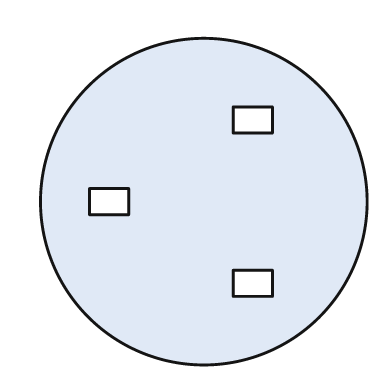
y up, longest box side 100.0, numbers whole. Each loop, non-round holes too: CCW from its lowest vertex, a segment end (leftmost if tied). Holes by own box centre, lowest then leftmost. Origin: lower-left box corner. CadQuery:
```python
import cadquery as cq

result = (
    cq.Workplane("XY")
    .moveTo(50.0, 50.0)
    .circle(50.0)
    .moveTo(59.0, 21.0)
    .lineTo(71.0, 21.0)
    .lineTo(71.0, 29.0)
    .lineTo(59.0, 29.0)
    .close()
    .moveTo(15.0, 46.0)
    .lineTo(27.0, 46.0)
    .lineTo(27.0, 54.0)
    .lineTo(15.0, 54.0)
    .close()
    .moveTo(59.0, 71.0)
    .lineTo(71.0, 71.0)
    .lineTo(71.0, 79.0)
    .lineTo(59.0, 79.0)
    .close()
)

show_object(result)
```